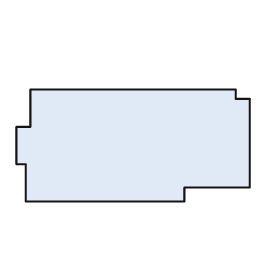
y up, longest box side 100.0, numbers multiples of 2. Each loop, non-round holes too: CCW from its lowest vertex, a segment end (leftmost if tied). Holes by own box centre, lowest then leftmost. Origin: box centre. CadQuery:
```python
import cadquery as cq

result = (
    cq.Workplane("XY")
    .moveTo(-46.0, -24.0)
    .lineTo(22.0, -24.0)
    .lineTo(22.0, -18.0)
    .lineTo(50.0, -18.0)
    .lineTo(50.0, 20.0)
    .lineTo(44.0, 20.0)
    .lineTo(44.0, 24.0)
    .lineTo(-44.0, 24.0)
    .lineTo(-44.0, 8.0)
    .lineTo(-50.0, 8.0)
    .lineTo(-50.0, -8.0)
    .lineTo(-46.0, -8.0)
    .close()
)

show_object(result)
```